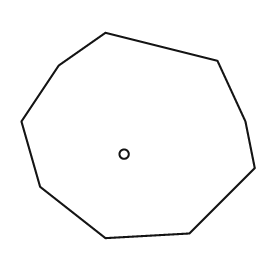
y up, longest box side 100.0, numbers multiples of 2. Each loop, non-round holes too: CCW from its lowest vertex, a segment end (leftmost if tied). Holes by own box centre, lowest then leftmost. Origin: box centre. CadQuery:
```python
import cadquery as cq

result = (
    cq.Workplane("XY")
    .moveTo(-14.0, -44.0)
    .lineTo(22.0, -42.0)
    .lineTo(50.0, -14.0)
    .lineTo(46.0, 6.0)
    .lineTo(34.0, 32.0)
    .lineTo(-14.0, 44.0)
    .lineTo(-34.0, 30.0)
    .lineTo(-50.0, 6.0)
    .lineTo(-42.0, -22.0)
    .close()
    .moveTo(-6.0, -8.0)
    .circle(2.0)
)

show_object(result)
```